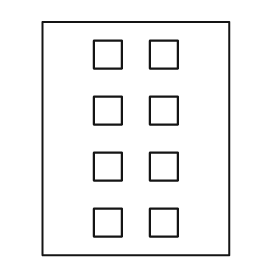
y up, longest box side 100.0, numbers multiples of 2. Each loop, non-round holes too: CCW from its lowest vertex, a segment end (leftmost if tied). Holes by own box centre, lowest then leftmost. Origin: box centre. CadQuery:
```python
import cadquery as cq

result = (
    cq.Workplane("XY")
    .moveTo(-40.0, -50.0)
    .lineTo(40.0, -50.0)
    .lineTo(40.0, 50.0)
    .lineTo(-40.0, 50.0)
    .close()
    .moveTo(-18.0, -42.0)
    .lineTo(-6.0, -42.0)
    .lineTo(-6.0, -30.0)
    .lineTo(-18.0, -30.0)
    .close()
    .moveTo(6.0, -42.0)
    .lineTo(18.0, -42.0)
    .lineTo(18.0, -30.0)
    .lineTo(6.0, -30.0)
    .close()
    .moveTo(-18.0, -18.0)
    .lineTo(-6.0, -18.0)
    .lineTo(-6.0, -6.0)
    .lineTo(-18.0, -6.0)
    .close()
    .moveTo(6.0, -18.0)
    .lineTo(18.0, -18.0)
    .lineTo(18.0, -6.0)
    .lineTo(6.0, -6.0)
    .close()
    .moveTo(-18.0, 6.0)
    .lineTo(-6.0, 6.0)
    .lineTo(-6.0, 18.0)
    .lineTo(-18.0, 18.0)
    .close()
    .moveTo(6.0, 6.0)
    .lineTo(18.0, 6.0)
    .lineTo(18.0, 18.0)
    .lineTo(6.0, 18.0)
    .close()
    .moveTo(-18.0, 30.0)
    .lineTo(-6.0, 30.0)
    .lineTo(-6.0, 42.0)
    .lineTo(-18.0, 42.0)
    .close()
    .moveTo(6.0, 30.0)
    .lineTo(18.0, 30.0)
    .lineTo(18.0, 42.0)
    .lineTo(6.0, 42.0)
    .close()
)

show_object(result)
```